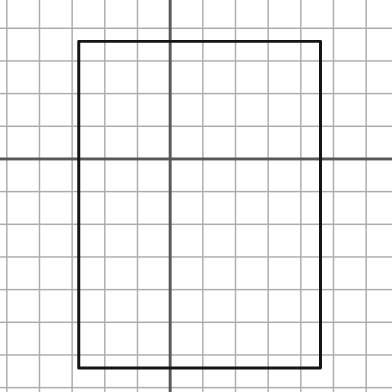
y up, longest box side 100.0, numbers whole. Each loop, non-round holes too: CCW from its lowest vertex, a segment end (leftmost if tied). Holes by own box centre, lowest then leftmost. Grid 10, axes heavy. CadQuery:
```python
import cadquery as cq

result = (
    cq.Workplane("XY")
    .moveTo(-28.0, -64.0)
    .lineTo(46.0, -64.0)
    .lineTo(46.0, 36.0)
    .lineTo(-28.0, 36.0)
    .close()
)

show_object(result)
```